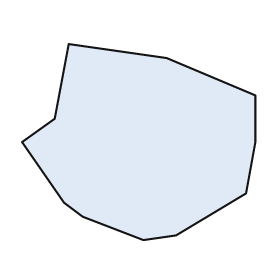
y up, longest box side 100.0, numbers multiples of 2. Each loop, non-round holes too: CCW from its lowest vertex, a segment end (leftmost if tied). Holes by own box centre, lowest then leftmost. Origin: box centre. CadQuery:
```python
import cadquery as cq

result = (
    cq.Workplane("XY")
    .moveTo(2.0, -42.0)
    .lineTo(16.0, -40.0)
    .lineTo(46.0, -22.0)
    .lineTo(50.0, 0.0)
    .lineTo(50.0, 20.0)
    .lineTo(12.0, 36.0)
    .lineTo(-30.0, 42.0)
    .lineTo(-36.0, 10.0)
    .lineTo(-50.0, 0.0)
    .lineTo(-32.0, -26.0)
    .lineTo(-24.0, -32.0)
    .close()
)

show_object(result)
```